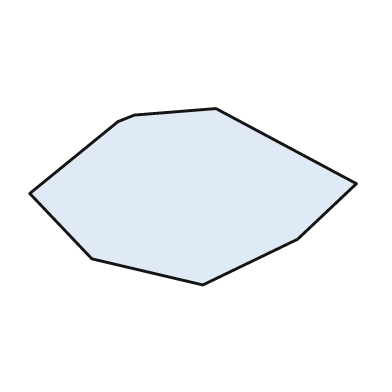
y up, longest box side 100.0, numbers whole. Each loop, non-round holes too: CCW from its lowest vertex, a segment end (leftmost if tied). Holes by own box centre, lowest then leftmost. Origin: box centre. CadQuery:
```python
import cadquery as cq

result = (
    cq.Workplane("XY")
    .moveTo(3.0, -27.0)
    .lineTo(32.0, -13.0)
    .lineTo(50.0, 4.0)
    .lineTo(7.0, 27.0)
    .lineTo(-18.0, 25.0)
    .lineTo(-23.0, 23.0)
    .lineTo(-50.0, 1.0)
    .lineTo(-31.0, -19.0)
    .close()
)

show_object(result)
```